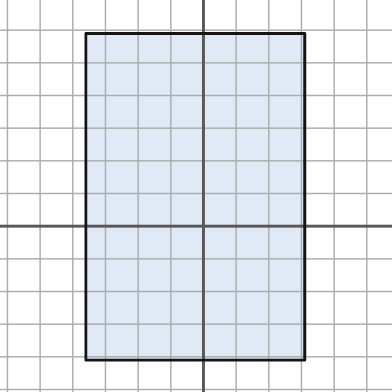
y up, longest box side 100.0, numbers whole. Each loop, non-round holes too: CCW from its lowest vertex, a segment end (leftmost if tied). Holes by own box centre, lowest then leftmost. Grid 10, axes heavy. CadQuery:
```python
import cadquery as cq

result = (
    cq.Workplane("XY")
    .moveTo(-36.0, -41.0)
    .lineTo(31.0, -41.0)
    .lineTo(31.0, 59.0)
    .lineTo(-36.0, 59.0)
    .close()
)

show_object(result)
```